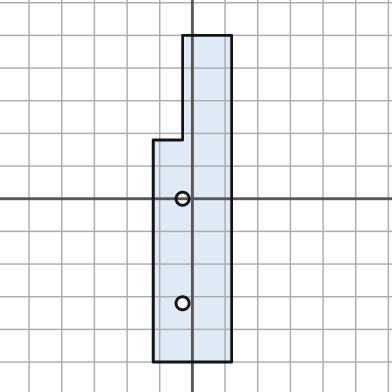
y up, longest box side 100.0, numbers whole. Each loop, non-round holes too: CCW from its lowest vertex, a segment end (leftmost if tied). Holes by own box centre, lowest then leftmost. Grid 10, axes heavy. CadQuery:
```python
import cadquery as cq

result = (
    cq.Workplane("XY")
    .moveTo(-12.0, -50.0)
    .lineTo(12.0, -50.0)
    .lineTo(12.0, 50.0)
    .lineTo(-3.0, 50.0)
    .lineTo(-3.0, 18.0)
    .lineTo(-12.0, 18.0)
    .close()
    .moveTo(-3.0, -32.0)
    .circle(2.0)
    .moveTo(-3.0, 0.0)
    .circle(2.0)
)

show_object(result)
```